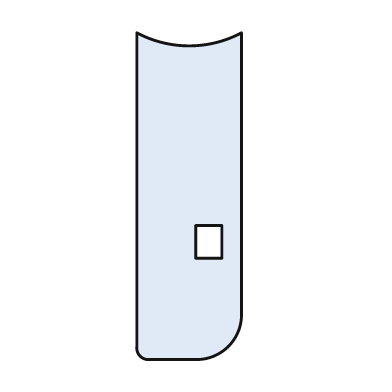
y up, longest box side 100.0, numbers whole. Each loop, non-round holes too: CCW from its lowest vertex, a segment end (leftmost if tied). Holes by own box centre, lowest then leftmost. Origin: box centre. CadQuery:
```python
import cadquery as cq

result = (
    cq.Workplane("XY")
    .moveTo(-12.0, -50.0)
    .lineTo(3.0, -50.0)
    .threePointArc((12.0, -46.0), (16.0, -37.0))
    .lineTo(16.0, 50.0)
    .threePointArc((0.0, 46.0), (-16.0, 50.0))
    .lineTo(-16.0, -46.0)
    .threePointArc((-15.0, -49.0), (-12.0, -50.0))
    .close()
    .moveTo(2.0, -19.0)
    .lineTo(10.0, -19.0)
    .lineTo(10.0, -9.0)
    .lineTo(2.0, -9.0)
    .close()
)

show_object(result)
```